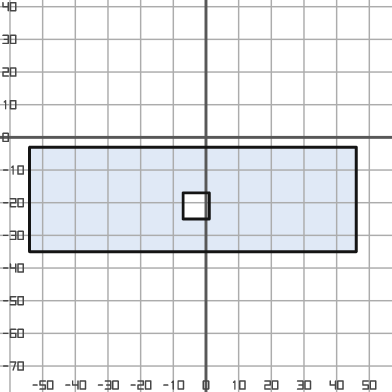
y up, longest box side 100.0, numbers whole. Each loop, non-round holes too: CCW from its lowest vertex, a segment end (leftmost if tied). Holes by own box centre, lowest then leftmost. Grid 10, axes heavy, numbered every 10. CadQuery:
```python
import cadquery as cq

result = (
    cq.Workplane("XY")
    .moveTo(-54.0, -35.0)
    .lineTo(46.0, -35.0)
    .lineTo(46.0, -3.0)
    .lineTo(-54.0, -3.0)
    .close()
    .moveTo(-7.0, -25.0)
    .lineTo(1.0, -25.0)
    .lineTo(1.0, -17.0)
    .lineTo(-7.0, -17.0)
    .close()
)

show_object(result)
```